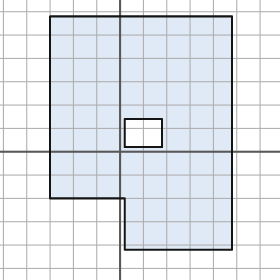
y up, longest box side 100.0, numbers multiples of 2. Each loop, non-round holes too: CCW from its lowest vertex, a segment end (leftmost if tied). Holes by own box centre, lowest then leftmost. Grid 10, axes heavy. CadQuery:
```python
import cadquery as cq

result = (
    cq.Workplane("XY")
    .moveTo(2.0, -42.0)
    .lineTo(48.0, -42.0)
    .lineTo(48.0, 58.0)
    .lineTo(-30.0, 58.0)
    .lineTo(-30.0, -20.0)
    .lineTo(2.0, -20.0)
    .close()
    .moveTo(2.0, 2.0)
    .lineTo(18.0, 2.0)
    .lineTo(18.0, 14.0)
    .lineTo(2.0, 14.0)
    .close()
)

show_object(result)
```